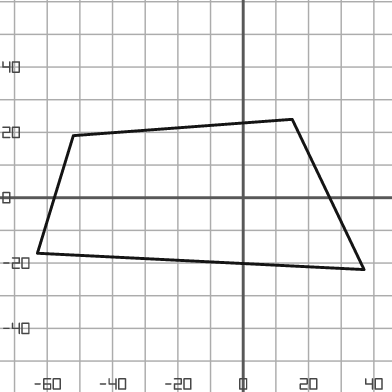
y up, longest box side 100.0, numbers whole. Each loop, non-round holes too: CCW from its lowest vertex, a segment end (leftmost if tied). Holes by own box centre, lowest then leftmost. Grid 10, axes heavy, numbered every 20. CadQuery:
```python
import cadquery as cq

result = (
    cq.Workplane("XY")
    .moveTo(37.0, -22.0)
    .lineTo(15.0, 24.0)
    .lineTo(-52.0, 19.0)
    .lineTo(-63.0, -17.0)
    .close()
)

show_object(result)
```